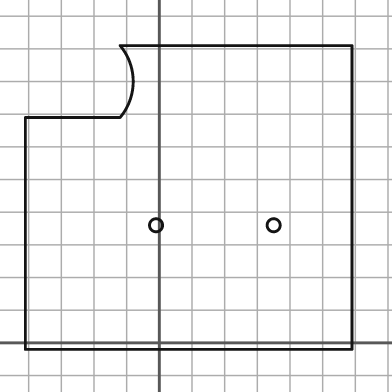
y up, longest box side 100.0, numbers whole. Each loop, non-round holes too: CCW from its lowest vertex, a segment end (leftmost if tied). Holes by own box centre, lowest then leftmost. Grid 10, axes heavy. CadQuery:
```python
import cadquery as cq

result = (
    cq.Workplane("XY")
    .moveTo(-41.0, -2.0)
    .lineTo(59.0, -2.0)
    .lineTo(59.0, 91.0)
    .lineTo(-12.0, 91.0)
    .threePointArc((-8.0, 80.0), (-12.0, 69.0))
    .lineTo(-41.0, 69.0)
    .close()
    .moveTo(-1.0, 36.0)
    .circle(2.0)
    .moveTo(35.0, 36.0)
    .circle(2.0)
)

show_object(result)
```